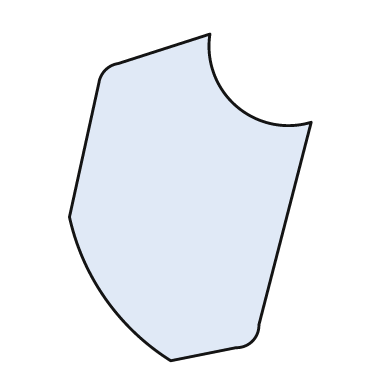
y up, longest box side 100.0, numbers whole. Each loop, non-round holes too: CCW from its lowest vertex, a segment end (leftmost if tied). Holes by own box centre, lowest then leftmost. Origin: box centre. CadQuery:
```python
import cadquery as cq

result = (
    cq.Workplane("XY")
    .moveTo(-6.0, -50.0)
    .lineTo(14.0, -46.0)
    .threePointArc((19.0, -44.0), (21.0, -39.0))
    .lineTo(37.0, 23.0)
    .threePointArc((14.0, 28.0), (6.0, 50.0))
    .lineTo(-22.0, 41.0)
    .threePointArc((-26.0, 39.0), (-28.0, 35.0))
    .lineTo(-37.0, -6.0)
    .threePointArc((-26.0, -31.0), (-6.0, -50.0))
    .close()
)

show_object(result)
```